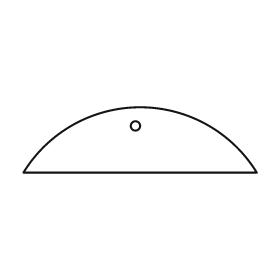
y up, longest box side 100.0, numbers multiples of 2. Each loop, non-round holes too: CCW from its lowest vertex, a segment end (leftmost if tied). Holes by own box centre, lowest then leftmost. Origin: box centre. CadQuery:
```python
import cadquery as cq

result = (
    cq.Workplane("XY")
    .moveTo(-50.0, -14.0)
    .lineTo(50.0, -14.0)
    .threePointArc((0.0, 14.0), (-50.0, -14.0))
    .close()
    .moveTo(-2.0, 6.0)
    .circle(2.0)
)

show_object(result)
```